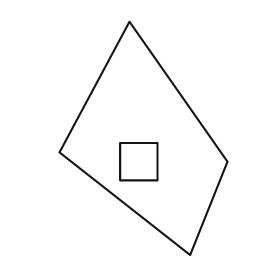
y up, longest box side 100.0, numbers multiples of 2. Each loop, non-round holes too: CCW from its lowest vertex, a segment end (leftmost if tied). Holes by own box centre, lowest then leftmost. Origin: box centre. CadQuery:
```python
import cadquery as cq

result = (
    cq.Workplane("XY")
    .moveTo(20.0, -50.0)
    .lineTo(36.0, -10.0)
    .lineTo(-6.0, 50.0)
    .lineTo(-36.0, -6.0)
    .close()
    .moveTo(-10.0, -18.0)
    .lineTo(6.0, -18.0)
    .lineTo(6.0, -2.0)
    .lineTo(-10.0, -2.0)
    .close()
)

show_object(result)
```